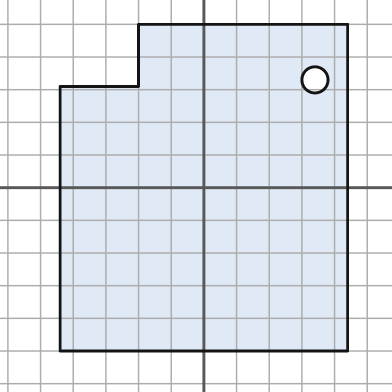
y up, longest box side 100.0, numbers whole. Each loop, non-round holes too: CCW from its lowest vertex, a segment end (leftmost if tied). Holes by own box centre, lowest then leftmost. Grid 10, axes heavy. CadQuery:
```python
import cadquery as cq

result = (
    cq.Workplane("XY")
    .moveTo(-44.0, -50.0)
    .lineTo(44.0, -50.0)
    .lineTo(44.0, 50.0)
    .lineTo(-20.0, 50.0)
    .lineTo(-20.0, 31.0)
    .lineTo(-44.0, 31.0)
    .close()
    .moveTo(34.0, 33.0)
    .circle(4.0)
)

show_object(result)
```